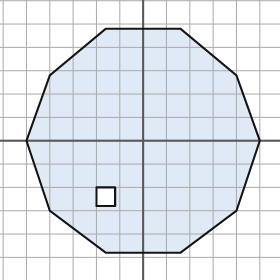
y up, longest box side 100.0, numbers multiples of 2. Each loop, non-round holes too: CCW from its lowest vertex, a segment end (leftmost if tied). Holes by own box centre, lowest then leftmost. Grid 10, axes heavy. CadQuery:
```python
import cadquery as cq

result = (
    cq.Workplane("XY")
    .moveTo(-16.0, -48.0)
    .lineTo(16.0, -48.0)
    .lineTo(40.0, -30.0)
    .lineTo(50.0, 0.0)
    .lineTo(40.0, 28.0)
    .lineTo(16.0, 48.0)
    .lineTo(-16.0, 48.0)
    .lineTo(-40.0, 28.0)
    .lineTo(-50.0, 0.0)
    .lineTo(-40.0, -30.0)
    .close()
    .moveTo(-20.0, -28.0)
    .lineTo(-12.0, -28.0)
    .lineTo(-12.0, -20.0)
    .lineTo(-20.0, -20.0)
    .close()
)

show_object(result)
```